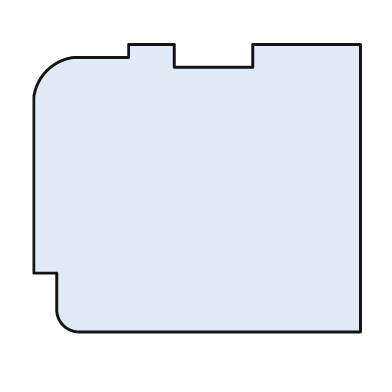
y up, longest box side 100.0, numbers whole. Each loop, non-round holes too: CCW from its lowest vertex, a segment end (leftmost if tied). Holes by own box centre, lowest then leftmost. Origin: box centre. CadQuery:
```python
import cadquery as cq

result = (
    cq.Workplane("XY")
    .moveTo(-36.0, -44.0)
    .lineTo(50.0, -44.0)
    .lineTo(50.0, 44.0)
    .lineTo(17.0, 44.0)
    .lineTo(17.0, 37.0)
    .lineTo(-7.0, 37.0)
    .lineTo(-7.0, 44.0)
    .lineTo(-21.0, 44.0)
    .lineTo(-21.0, 40.0)
    .lineTo(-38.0, 40.0)
    .threePointArc((-46.0, 36.0), (-50.0, 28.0))
    .lineTo(-50.0, -26.0)
    .lineTo(-43.0, -26.0)
    .lineTo(-43.0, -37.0)
    .threePointArc((-41.0, -42.0), (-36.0, -44.0))
    .close()
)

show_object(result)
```